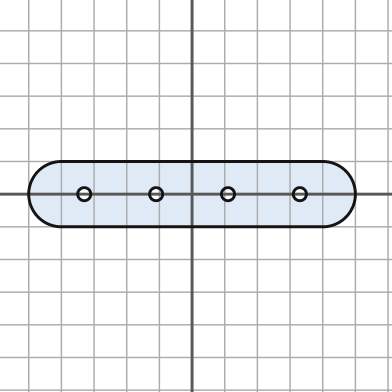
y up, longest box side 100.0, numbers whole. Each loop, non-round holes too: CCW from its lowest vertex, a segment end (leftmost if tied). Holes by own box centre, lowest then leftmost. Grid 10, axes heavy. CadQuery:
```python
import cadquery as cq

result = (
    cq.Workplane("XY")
    .moveTo(-40.0, -10.0)
    .lineTo(40.0, -10.0)
    .threePointArc((50.0, 0.0), (40.0, 10.0))
    .lineTo(-40.0, 10.0)
    .threePointArc((-50.0, 0.0), (-40.0, -10.0))
    .close()
    .moveTo(-33.0, 0.0)
    .circle(2.0)
    .moveTo(-11.0, 0.0)
    .circle(2.0)
    .moveTo(11.0, 0.0)
    .circle(2.0)
    .moveTo(33.0, 0.0)
    .circle(2.0)
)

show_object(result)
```